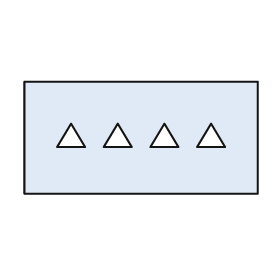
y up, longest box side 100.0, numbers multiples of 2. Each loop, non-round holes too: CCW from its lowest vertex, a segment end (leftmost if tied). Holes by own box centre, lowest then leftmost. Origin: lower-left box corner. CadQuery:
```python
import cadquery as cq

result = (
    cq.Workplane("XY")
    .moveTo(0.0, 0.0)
    .lineTo(100.0, 0.0)
    .lineTo(100.0, 48.0)
    .lineTo(0.0, 48.0)
    .close()
    .moveTo(14.0, 20.0)
    .lineTo(26.0, 20.0)
    .lineTo(20.0, 30.0)
    .close()
    .moveTo(34.0, 20.0)
    .lineTo(46.0, 20.0)
    .lineTo(40.0, 30.0)
    .close()
    .moveTo(54.0, 20.0)
    .lineTo(66.0, 20.0)
    .lineTo(60.0, 30.0)
    .close()
    .moveTo(74.0, 20.0)
    .lineTo(86.0, 20.0)
    .lineTo(80.0, 30.0)
    .close()
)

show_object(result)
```